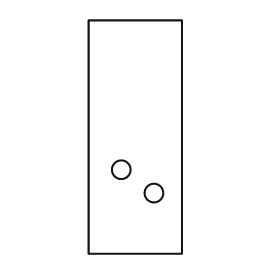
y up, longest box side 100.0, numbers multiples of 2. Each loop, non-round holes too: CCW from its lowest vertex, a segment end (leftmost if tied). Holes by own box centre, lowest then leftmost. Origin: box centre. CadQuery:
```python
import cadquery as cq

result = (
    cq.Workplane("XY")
    .moveTo(-20.0, -50.0)
    .lineTo(20.0, -50.0)
    .lineTo(20.0, 50.0)
    .lineTo(-20.0, 50.0)
    .close()
    .moveTo(8.0, -24.0)
    .circle(4.0)
    .moveTo(-6.0, -14.0)
    .circle(4.0)
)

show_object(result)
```